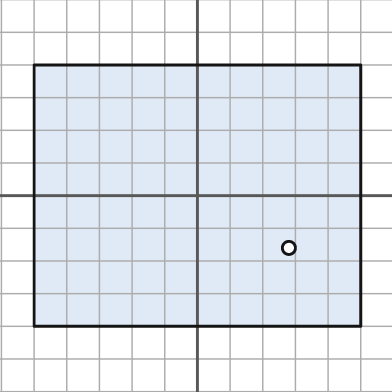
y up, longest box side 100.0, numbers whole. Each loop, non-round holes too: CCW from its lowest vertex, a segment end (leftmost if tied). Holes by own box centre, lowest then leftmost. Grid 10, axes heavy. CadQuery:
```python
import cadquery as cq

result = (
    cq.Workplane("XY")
    .moveTo(-50.0, -40.0)
    .lineTo(50.0, -40.0)
    .lineTo(50.0, 40.0)
    .lineTo(-50.0, 40.0)
    .close()
    .moveTo(28.0, -16.0)
    .circle(2.0)
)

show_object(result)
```